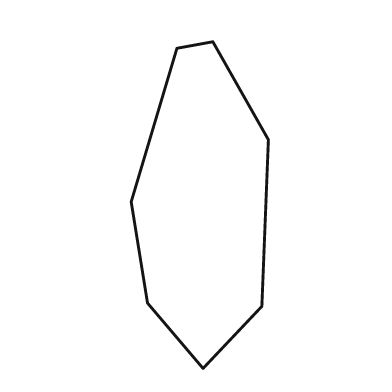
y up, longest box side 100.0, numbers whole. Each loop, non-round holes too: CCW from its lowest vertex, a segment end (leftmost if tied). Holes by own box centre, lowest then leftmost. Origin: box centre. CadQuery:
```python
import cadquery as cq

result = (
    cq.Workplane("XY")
    .moveTo(1.0, -50.0)
    .lineTo(19.0, -31.0)
    .lineTo(21.0, 20.0)
    .lineTo(4.0, 50.0)
    .lineTo(-7.0, 48.0)
    .lineTo(-21.0, 1.0)
    .lineTo(-16.0, -30.0)
    .close()
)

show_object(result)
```